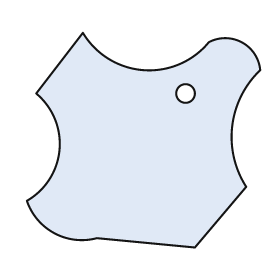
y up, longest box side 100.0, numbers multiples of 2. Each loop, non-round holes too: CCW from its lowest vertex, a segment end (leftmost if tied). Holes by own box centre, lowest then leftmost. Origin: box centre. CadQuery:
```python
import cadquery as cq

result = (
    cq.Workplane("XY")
    .moveTo(22.0, -46.0)
    .lineTo(44.0, -20.0)
    .threePointArc((38.0, 6.0), (50.0, 30.0))
    .threePointArc((42.0, 42.0), (28.0, 42.0))
    .threePointArc((0.0, 30.0), (-26.0, 46.0))
    .lineTo(-46.0, 20.0)
    .threePointArc((-36.0, -4.0), (-50.0, -26.0))
    .threePointArc((-38.0, -40.0), (-20.0, -42.0))
    .close()
    .moveTo(18.0, 20.0)
    .circle(4.0)
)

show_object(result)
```